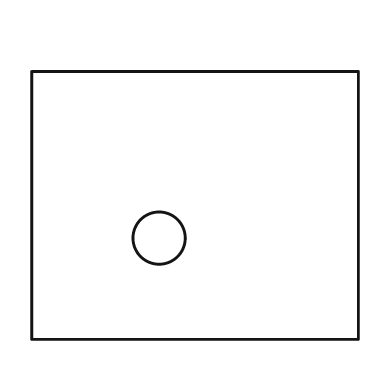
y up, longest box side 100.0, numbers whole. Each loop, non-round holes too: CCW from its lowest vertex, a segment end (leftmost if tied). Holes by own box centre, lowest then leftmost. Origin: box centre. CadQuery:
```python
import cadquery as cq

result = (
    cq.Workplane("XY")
    .moveTo(-50.0, -41.0)
    .lineTo(50.0, -41.0)
    .lineTo(50.0, 41.0)
    .lineTo(-50.0, 41.0)
    .close()
    .moveTo(-11.0, -10.0)
    .circle(8.0)
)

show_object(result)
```